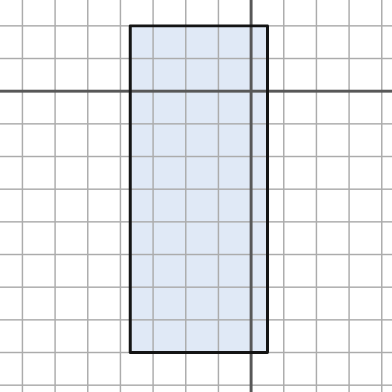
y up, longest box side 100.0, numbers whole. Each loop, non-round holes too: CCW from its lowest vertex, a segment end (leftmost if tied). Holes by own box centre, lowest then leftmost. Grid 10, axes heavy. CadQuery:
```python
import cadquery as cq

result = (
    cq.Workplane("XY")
    .moveTo(-37.0, -80.0)
    .lineTo(5.0, -80.0)
    .lineTo(5.0, 20.0)
    .lineTo(-37.0, 20.0)
    .close()
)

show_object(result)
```